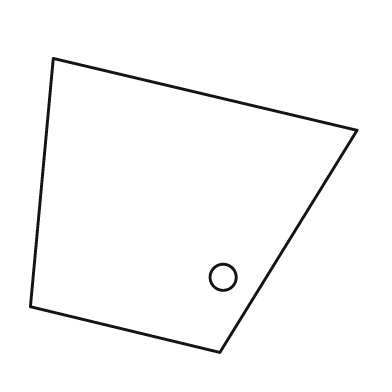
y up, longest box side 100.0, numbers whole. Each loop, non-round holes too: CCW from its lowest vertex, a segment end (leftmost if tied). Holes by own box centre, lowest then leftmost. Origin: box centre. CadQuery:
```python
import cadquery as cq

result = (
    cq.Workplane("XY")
    .moveTo(8.0, -45.0)
    .lineTo(50.0, 23.0)
    .lineTo(-43.0, 45.0)
    .lineTo(-50.0, -31.0)
    .close()
    .moveTo(9.0, -22.0)
    .circle(4.0)
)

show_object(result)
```